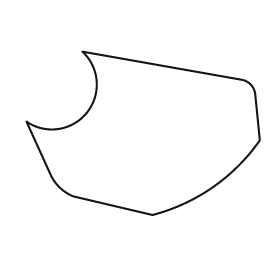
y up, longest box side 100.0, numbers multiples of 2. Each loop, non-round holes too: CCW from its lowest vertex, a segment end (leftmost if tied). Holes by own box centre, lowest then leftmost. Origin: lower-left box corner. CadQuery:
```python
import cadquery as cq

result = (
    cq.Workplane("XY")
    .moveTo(54.0, 0.0)
    .threePointArc((80.0, 12.0), (100.0, 32.0))
    .lineTo(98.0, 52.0)
    .threePointArc((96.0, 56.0), (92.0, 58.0))
    .lineTo(24.0, 70.0)
    .threePointArc((26.0, 44.0), (0.0, 40.0))
    .lineTo(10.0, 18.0)
    .threePointArc((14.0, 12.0), (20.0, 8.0))
    .close()
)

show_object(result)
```